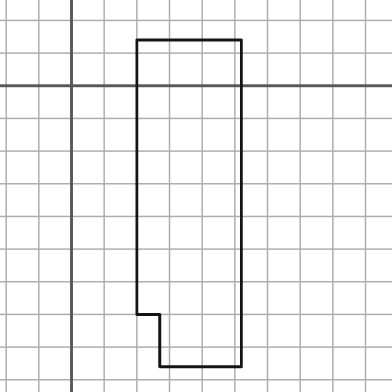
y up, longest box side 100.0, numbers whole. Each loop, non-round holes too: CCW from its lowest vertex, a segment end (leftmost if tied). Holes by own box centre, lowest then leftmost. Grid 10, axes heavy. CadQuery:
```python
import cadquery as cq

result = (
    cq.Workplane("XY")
    .moveTo(27.0, -86.0)
    .lineTo(52.0, -86.0)
    .lineTo(52.0, 14.0)
    .lineTo(20.0, 14.0)
    .lineTo(20.0, -70.0)
    .lineTo(27.0, -70.0)
    .close()
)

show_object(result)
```